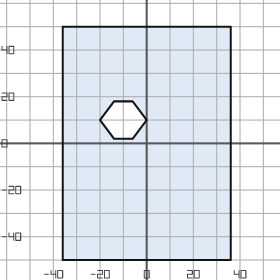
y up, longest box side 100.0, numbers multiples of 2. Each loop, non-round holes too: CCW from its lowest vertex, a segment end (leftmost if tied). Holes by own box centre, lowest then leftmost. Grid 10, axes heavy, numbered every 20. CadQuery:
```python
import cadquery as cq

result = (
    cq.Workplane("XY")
    .moveTo(-36.0, -50.0)
    .lineTo(36.0, -50.0)
    .lineTo(36.0, 50.0)
    .lineTo(-36.0, 50.0)
    .close()
    .moveTo(-14.0, 2.0)
    .lineTo(-6.0, 2.0)
    .lineTo(0.0, 10.0)
    .lineTo(-6.0, 18.0)
    .lineTo(-14.0, 18.0)
    .lineTo(-20.0, 10.0)
    .close()
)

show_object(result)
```